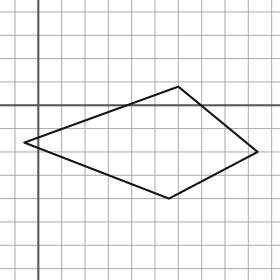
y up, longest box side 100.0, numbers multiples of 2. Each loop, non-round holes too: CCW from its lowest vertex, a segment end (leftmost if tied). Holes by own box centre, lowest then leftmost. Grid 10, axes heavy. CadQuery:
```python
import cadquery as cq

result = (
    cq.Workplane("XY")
    .moveTo(56.0, -40.0)
    .lineTo(94.0, -20.0)
    .lineTo(60.0, 8.0)
    .lineTo(-6.0, -16.0)
    .close()
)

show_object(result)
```